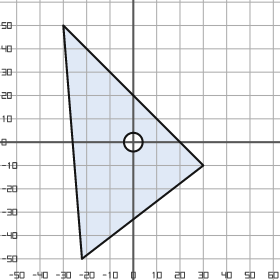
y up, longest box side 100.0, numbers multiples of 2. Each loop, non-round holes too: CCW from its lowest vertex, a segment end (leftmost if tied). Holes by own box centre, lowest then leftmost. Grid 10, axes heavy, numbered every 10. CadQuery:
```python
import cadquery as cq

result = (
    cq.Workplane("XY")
    .moveTo(-22.0, -50.0)
    .lineTo(30.0, -10.0)
    .lineTo(-30.0, 50.0)
    .close()
    .moveTo(0.0, 0.0)
    .circle(4.0)
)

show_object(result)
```